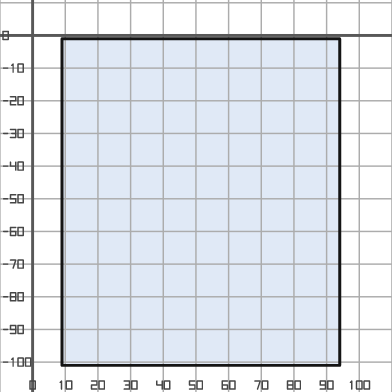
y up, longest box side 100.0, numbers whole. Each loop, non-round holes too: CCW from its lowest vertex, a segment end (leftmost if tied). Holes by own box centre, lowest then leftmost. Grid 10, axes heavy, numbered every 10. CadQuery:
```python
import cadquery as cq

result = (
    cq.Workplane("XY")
    .moveTo(9.0, -101.0)
    .lineTo(94.0, -101.0)
    .lineTo(94.0, -1.0)
    .lineTo(9.0, -1.0)
    .close()
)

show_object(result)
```